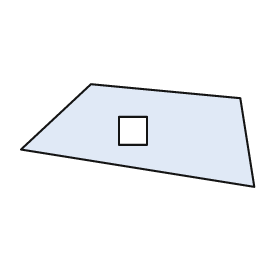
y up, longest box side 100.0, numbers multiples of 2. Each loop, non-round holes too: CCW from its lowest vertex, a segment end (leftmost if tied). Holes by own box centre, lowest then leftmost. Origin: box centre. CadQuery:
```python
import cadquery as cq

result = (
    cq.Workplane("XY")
    .moveTo(50.0, -22.0)
    .lineTo(44.0, 16.0)
    .lineTo(-20.0, 22.0)
    .lineTo(-50.0, -6.0)
    .close()
    .moveTo(-8.0, -4.0)
    .lineTo(4.0, -4.0)
    .lineTo(4.0, 8.0)
    .lineTo(-8.0, 8.0)
    .close()
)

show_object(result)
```